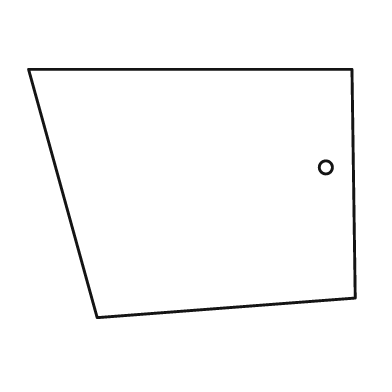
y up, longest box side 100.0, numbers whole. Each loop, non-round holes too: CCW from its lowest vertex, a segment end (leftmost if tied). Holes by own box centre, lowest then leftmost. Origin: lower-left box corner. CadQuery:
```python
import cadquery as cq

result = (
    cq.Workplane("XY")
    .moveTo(21.0, 0.0)
    .lineTo(100.0, 6.0)
    .lineTo(99.0, 76.0)
    .lineTo(0.0, 76.0)
    .close()
    .moveTo(91.0, 46.0)
    .circle(2.0)
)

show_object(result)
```